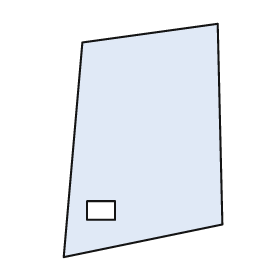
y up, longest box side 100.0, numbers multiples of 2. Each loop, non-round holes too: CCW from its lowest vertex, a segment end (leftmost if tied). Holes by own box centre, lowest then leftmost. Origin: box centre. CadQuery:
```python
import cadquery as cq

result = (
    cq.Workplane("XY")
    .moveTo(-34.0, -50.0)
    .lineTo(34.0, -36.0)
    .lineTo(32.0, 50.0)
    .lineTo(-26.0, 42.0)
    .close()
    .moveTo(-24.0, -34.0)
    .lineTo(-12.0, -34.0)
    .lineTo(-12.0, -26.0)
    .lineTo(-24.0, -26.0)
    .close()
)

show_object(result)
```